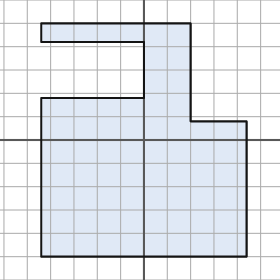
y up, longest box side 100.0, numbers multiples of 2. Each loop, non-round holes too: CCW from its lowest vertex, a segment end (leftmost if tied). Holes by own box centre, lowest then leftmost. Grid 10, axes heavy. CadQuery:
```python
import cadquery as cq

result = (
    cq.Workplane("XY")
    .moveTo(-44.0, -50.0)
    .lineTo(44.0, -50.0)
    .lineTo(44.0, 8.0)
    .lineTo(20.0, 8.0)
    .lineTo(20.0, 50.0)
    .lineTo(-44.0, 50.0)
    .lineTo(-44.0, 42.0)
    .lineTo(0.0, 42.0)
    .lineTo(0.0, 18.0)
    .lineTo(-44.0, 18.0)
    .close()
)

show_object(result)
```